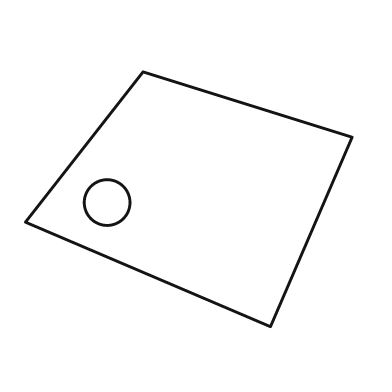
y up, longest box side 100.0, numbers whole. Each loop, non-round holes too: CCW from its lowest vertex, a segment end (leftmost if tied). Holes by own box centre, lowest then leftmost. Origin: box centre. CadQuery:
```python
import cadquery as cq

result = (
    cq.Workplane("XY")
    .moveTo(25.0, -39.0)
    .lineTo(50.0, 19.0)
    .lineTo(-14.0, 39.0)
    .lineTo(-50.0, -7.0)
    .close()
    .moveTo(-25.0, -1.0)
    .circle(7.0)
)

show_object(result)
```